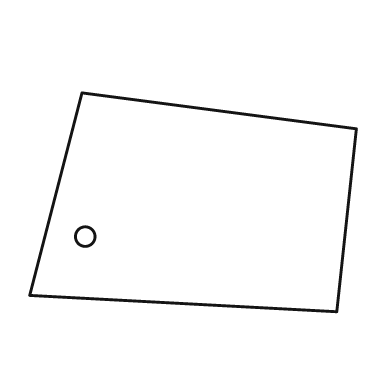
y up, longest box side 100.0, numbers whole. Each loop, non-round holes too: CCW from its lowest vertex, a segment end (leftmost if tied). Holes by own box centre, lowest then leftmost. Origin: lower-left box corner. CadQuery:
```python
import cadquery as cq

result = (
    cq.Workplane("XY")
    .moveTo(94.0, 0.0)
    .lineTo(100.0, 56.0)
    .lineTo(16.0, 67.0)
    .lineTo(0.0, 5.0)
    .close()
    .moveTo(17.0, 23.0)
    .circle(3.0)
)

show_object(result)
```